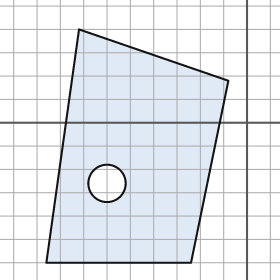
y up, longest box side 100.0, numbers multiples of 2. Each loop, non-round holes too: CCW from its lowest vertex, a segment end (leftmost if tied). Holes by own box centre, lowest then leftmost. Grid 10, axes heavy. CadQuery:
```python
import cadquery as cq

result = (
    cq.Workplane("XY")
    .moveTo(-86.0, -60.0)
    .lineTo(-24.0, -60.0)
    .lineTo(-8.0, 18.0)
    .lineTo(-72.0, 40.0)
    .close()
    .moveTo(-60.0, -26.0)
    .circle(8.0)
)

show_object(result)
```